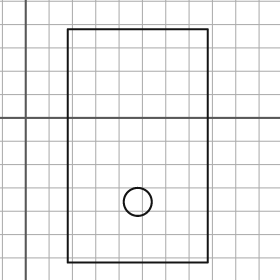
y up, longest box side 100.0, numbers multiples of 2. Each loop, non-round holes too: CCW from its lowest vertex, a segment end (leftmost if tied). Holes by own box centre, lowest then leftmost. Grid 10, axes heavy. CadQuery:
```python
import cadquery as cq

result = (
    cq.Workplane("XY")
    .moveTo(18.0, -62.0)
    .lineTo(78.0, -62.0)
    .lineTo(78.0, 38.0)
    .lineTo(18.0, 38.0)
    .close()
    .moveTo(48.0, -36.0)
    .circle(6.0)
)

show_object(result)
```